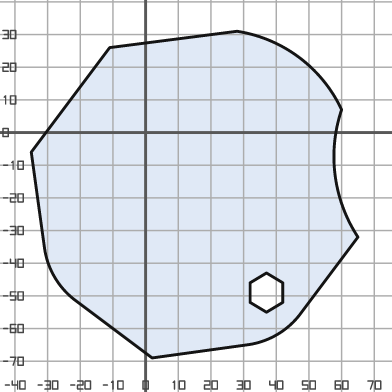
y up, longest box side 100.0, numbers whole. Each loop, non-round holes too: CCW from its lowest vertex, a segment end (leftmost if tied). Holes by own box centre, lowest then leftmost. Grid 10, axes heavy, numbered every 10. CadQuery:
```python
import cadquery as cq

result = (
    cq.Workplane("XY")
    .moveTo(2.0, -69.0)
    .lineTo(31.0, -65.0)
    .threePointArc((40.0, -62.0), (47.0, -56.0))
    .lineTo(65.0, -32.0)
    .threePointArc((58.0, -13.0), (60.0, 7.0))
    .threePointArc((47.0, 23.0), (28.0, 31.0))
    .lineTo(-11.0, 26.0)
    .lineTo(-35.0, -6.0)
    .lineTo(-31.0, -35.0)
    .threePointArc((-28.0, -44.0), (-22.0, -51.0))
    .close()
    .moveTo(37.0, -55.0)
    .lineTo(42.0, -52.0)
    .lineTo(42.0, -46.0)
    .lineTo(37.0, -43.0)
    .lineTo(32.0, -46.0)
    .lineTo(32.0, -52.0)
    .close()
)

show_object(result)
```